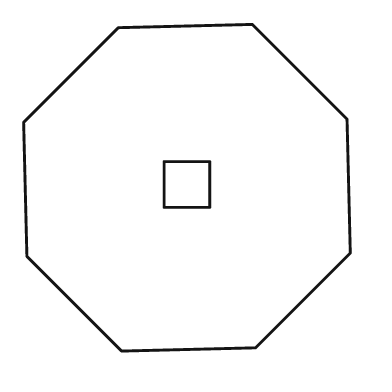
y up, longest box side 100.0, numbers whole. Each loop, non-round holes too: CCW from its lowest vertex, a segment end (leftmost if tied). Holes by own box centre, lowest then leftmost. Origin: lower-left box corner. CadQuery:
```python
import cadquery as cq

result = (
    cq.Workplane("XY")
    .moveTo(30.0, 0.0)
    .lineTo(71.0, 1.0)
    .lineTo(100.0, 30.0)
    .lineTo(99.0, 71.0)
    .lineTo(70.0, 100.0)
    .lineTo(29.0, 99.0)
    .lineTo(0.0, 70.0)
    .lineTo(1.0, 29.0)
    .close()
    .moveTo(43.0, 44.0)
    .lineTo(57.0, 44.0)
    .lineTo(57.0, 58.0)
    .lineTo(43.0, 58.0)
    .close()
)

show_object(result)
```